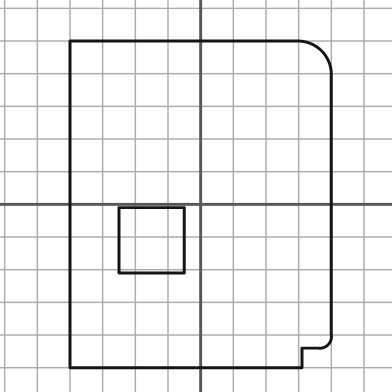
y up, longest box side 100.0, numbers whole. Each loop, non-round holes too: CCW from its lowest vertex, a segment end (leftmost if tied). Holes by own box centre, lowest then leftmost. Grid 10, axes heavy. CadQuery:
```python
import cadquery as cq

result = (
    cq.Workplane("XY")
    .moveTo(-40.0, -50.0)
    .lineTo(31.0, -50.0)
    .lineTo(31.0, -44.0)
    .lineTo(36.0, -44.0)
    .threePointArc((39.0, -43.0), (40.0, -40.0))
    .lineTo(40.0, 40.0)
    .threePointArc((37.0, 47.0), (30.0, 50.0))
    .lineTo(-40.0, 50.0)
    .close()
    .moveTo(-25.0, -21.0)
    .lineTo(-5.0, -21.0)
    .lineTo(-5.0, -1.0)
    .lineTo(-25.0, -1.0)
    .close()
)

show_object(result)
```